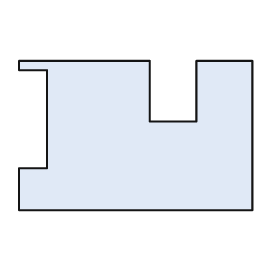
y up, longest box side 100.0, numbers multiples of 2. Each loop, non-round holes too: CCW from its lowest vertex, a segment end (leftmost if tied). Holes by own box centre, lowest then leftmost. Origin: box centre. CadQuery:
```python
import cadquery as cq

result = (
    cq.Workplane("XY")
    .moveTo(-50.0, -32.0)
    .lineTo(50.0, -32.0)
    .lineTo(50.0, 32.0)
    .lineTo(26.0, 32.0)
    .lineTo(26.0, 6.0)
    .lineTo(6.0, 6.0)
    .lineTo(6.0, 32.0)
    .lineTo(-50.0, 32.0)
    .lineTo(-50.0, 28.0)
    .lineTo(-38.0, 28.0)
    .lineTo(-38.0, -14.0)
    .lineTo(-50.0, -14.0)
    .close()
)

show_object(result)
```